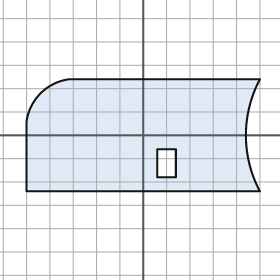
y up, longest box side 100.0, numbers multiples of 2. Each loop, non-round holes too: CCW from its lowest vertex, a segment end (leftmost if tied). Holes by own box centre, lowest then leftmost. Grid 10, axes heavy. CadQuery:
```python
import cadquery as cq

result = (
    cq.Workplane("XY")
    .moveTo(-50.0, -24.0)
    .lineTo(50.0, -24.0)
    .threePointArc((44.0, 0.0), (50.0, 24.0))
    .lineTo(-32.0, 24.0)
    .threePointArc((-44.0, 18.0), (-50.0, 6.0))
    .close()
    .moveTo(6.0, -18.0)
    .lineTo(14.0, -18.0)
    .lineTo(14.0, -6.0)
    .lineTo(6.0, -6.0)
    .close()
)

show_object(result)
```